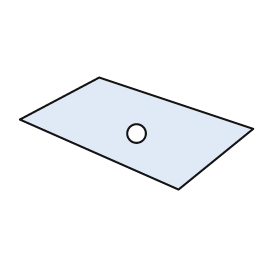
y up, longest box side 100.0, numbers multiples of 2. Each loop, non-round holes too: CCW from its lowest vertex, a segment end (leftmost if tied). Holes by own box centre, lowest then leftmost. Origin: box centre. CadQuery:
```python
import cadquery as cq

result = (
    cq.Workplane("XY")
    .moveTo(18.0, -24.0)
    .lineTo(50.0, 2.0)
    .lineTo(-16.0, 24.0)
    .lineTo(-50.0, 6.0)
    .close()
    .moveTo(0.0, 0.0)
    .circle(4.0)
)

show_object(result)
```